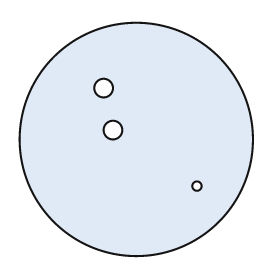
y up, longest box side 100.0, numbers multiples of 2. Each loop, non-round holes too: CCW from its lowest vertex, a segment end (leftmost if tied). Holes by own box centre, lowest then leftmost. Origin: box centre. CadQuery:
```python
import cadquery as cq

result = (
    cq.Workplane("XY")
    .moveTo(0.0, 0.0)
    .circle(50.0)
    .moveTo(26.0, -20.0)
    .circle(2.0)
    .moveTo(-10.0, 4.0)
    .circle(4.0)
    .moveTo(-14.0, 22.0)
    .circle(4.0)
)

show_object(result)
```